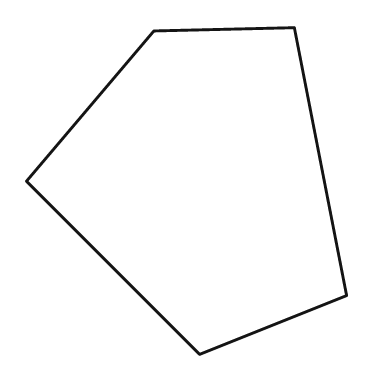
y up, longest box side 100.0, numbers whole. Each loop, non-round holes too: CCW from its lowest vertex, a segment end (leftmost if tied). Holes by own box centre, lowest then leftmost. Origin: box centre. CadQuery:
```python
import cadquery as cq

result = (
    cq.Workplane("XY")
    .moveTo(4.0, -50.0)
    .lineTo(49.0, -32.0)
    .lineTo(33.0, 50.0)
    .lineTo(-10.0, 49.0)
    .lineTo(-49.0, 3.0)
    .close()
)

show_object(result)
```